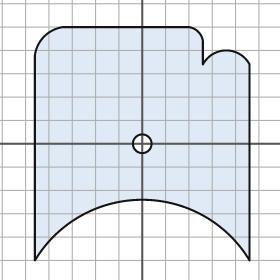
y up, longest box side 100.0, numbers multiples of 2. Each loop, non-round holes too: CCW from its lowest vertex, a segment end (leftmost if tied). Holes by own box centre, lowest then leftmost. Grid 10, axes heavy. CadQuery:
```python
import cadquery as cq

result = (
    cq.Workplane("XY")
    .moveTo(-46.0, -50.0)
    .threePointArc((0.0, -24.0), (46.0, -50.0))
    .lineTo(46.0, 34.0)
    .threePointArc((36.0, 40.0), (26.0, 34.0))
    .lineTo(26.0, 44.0)
    .threePointArc((24.0, 48.0), (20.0, 50.0))
    .lineTo(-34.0, 50.0)
    .threePointArc((-42.0, 46.0), (-46.0, 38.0))
    .close()
    .moveTo(0.0, 0.0)
    .circle(4.0)
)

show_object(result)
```